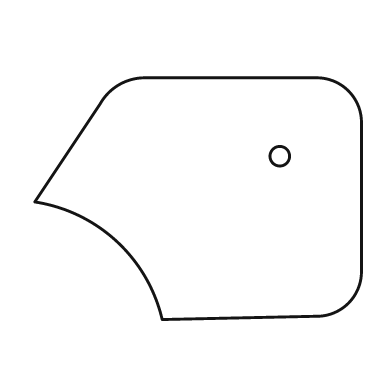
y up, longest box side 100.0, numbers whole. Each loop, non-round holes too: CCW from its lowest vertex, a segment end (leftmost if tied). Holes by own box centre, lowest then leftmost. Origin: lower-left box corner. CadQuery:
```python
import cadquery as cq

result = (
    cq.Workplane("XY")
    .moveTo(39.0, 0.0)
    .lineTo(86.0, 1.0)
    .threePointArc((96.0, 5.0), (100.0, 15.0))
    .lineTo(100.0, 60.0)
    .threePointArc((96.0, 70.0), (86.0, 74.0))
    .lineTo(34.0, 74.0)
    .threePointArc((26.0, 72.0), (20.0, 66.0))
    .lineTo(0.0, 36.0)
    .threePointArc((25.0, 24.0), (39.0, 0.0))
    .close()
    .moveTo(75.0, 50.0)
    .circle(3.0)
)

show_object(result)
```